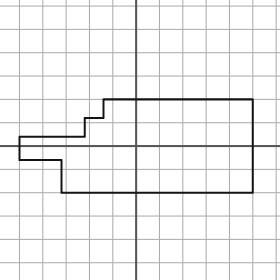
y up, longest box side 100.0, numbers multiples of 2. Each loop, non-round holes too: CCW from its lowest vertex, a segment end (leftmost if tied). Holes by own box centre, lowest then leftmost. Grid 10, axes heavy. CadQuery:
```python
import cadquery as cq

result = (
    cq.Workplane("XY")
    .moveTo(-32.0, -20.0)
    .lineTo(50.0, -20.0)
    .lineTo(50.0, 20.0)
    .lineTo(-14.0, 20.0)
    .lineTo(-14.0, 12.0)
    .lineTo(-22.0, 12.0)
    .lineTo(-22.0, 4.0)
    .lineTo(-50.0, 4.0)
    .lineTo(-50.0, -6.0)
    .lineTo(-32.0, -6.0)
    .close()
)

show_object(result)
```